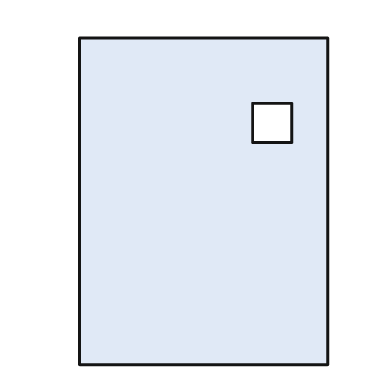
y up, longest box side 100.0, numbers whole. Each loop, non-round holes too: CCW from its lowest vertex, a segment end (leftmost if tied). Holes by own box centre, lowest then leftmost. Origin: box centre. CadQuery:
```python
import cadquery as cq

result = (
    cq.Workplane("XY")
    .moveTo(-38.0, -50.0)
    .lineTo(38.0, -50.0)
    .lineTo(38.0, 50.0)
    .lineTo(-38.0, 50.0)
    .close()
    .moveTo(15.0, 18.0)
    .lineTo(27.0, 18.0)
    .lineTo(27.0, 30.0)
    .lineTo(15.0, 30.0)
    .close()
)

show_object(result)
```